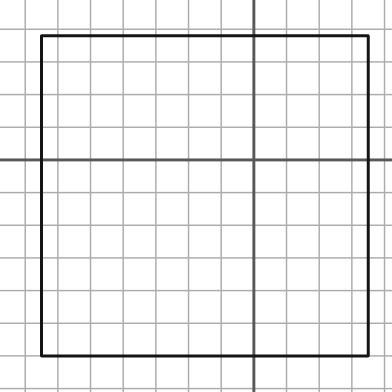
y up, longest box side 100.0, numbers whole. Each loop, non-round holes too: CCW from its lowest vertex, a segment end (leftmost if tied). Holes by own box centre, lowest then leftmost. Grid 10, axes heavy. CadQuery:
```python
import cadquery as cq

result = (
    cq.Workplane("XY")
    .moveTo(-65.0, -60.0)
    .lineTo(35.0, -60.0)
    .lineTo(35.0, 38.0)
    .lineTo(-65.0, 38.0)
    .close()
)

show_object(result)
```